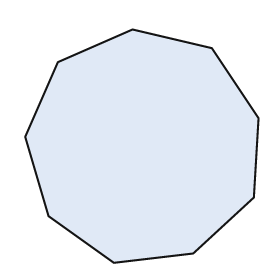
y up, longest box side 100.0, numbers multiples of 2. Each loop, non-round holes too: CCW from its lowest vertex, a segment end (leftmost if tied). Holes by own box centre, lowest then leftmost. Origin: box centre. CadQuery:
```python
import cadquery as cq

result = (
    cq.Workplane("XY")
    .moveTo(-12.0, -50.0)
    .lineTo(22.0, -46.0)
    .lineTo(48.0, -22.0)
    .lineTo(50.0, 12.0)
    .lineTo(30.0, 42.0)
    .lineTo(-4.0, 50.0)
    .lineTo(-36.0, 36.0)
    .lineTo(-50.0, 4.0)
    .lineTo(-40.0, -30.0)
    .close()
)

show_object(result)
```